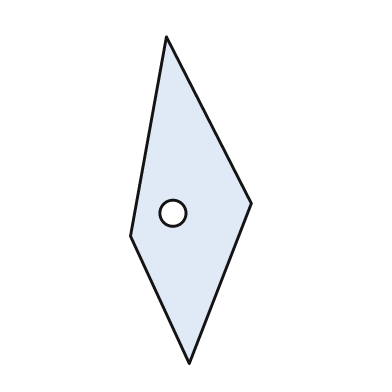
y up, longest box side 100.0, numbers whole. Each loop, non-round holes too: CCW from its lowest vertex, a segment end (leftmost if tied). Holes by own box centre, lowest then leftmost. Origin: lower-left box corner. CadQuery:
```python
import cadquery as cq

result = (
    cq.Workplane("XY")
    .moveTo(18.0, 0.0)
    .lineTo(37.0, 49.0)
    .lineTo(11.0, 100.0)
    .lineTo(0.0, 39.0)
    .close()
    .moveTo(13.0, 46.0)
    .circle(4.0)
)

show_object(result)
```